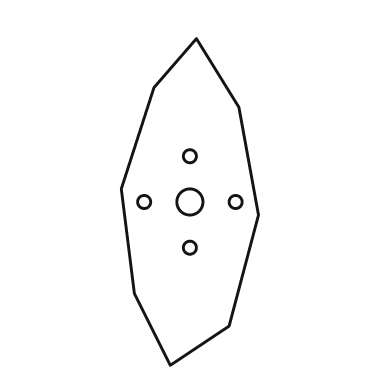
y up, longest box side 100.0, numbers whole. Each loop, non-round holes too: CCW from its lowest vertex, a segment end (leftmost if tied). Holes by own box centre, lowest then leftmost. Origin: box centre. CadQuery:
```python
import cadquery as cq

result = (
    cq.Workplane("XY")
    .moveTo(-6.0, -50.0)
    .lineTo(12.0, -38.0)
    .lineTo(21.0, -4.0)
    .lineTo(15.0, 29.0)
    .lineTo(2.0, 50.0)
    .lineTo(-11.0, 35.0)
    .lineTo(-21.0, 4.0)
    .lineTo(-17.0, -28.0)
    .close()
    .moveTo(0.0, -14.0)
    .circle(2.0)
    .moveTo(-14.0, 0.0)
    .circle(2.0)
    .moveTo(0.0, 0.0)
    .circle(4.0)
    .moveTo(14.0, 0.0)
    .circle(2.0)
    .moveTo(0.0, 14.0)
    .circle(2.0)
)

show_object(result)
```